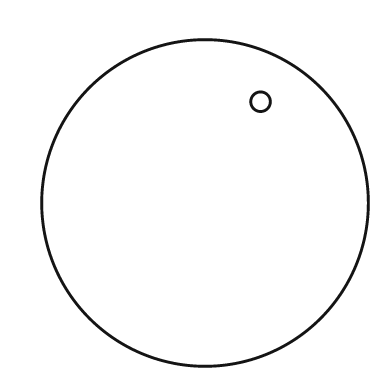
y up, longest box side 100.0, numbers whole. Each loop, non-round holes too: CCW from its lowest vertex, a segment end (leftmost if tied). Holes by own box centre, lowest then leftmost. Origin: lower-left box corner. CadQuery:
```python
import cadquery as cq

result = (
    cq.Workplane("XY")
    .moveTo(50.0, 50.0)
    .circle(50.0)
    .moveTo(67.0, 81.0)
    .circle(3.0)
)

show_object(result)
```